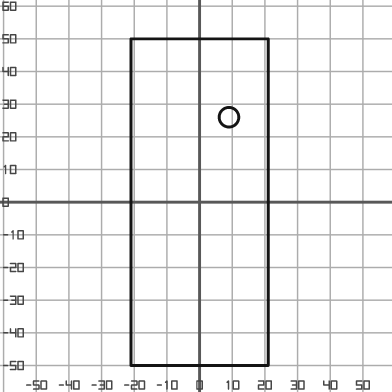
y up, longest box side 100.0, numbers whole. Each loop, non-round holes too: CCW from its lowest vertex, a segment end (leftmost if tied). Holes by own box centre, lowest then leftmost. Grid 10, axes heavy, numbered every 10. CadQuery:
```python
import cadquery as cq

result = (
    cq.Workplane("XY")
    .moveTo(-21.0, -50.0)
    .lineTo(21.0, -50.0)
    .lineTo(21.0, 50.0)
    .lineTo(-21.0, 50.0)
    .close()
    .moveTo(9.0, 26.0)
    .circle(3.0)
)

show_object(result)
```